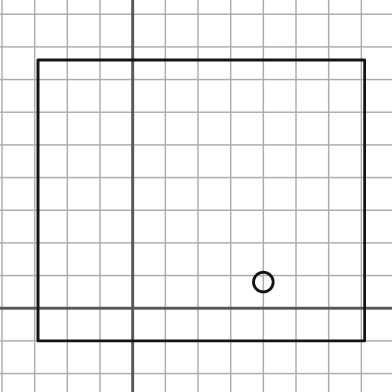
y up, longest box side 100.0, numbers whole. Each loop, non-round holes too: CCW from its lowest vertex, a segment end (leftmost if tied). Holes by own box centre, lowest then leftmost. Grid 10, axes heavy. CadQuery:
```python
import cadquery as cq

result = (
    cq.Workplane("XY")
    .moveTo(-29.0, -10.0)
    .lineTo(71.0, -10.0)
    .lineTo(71.0, 76.0)
    .lineTo(-29.0, 76.0)
    .close()
    .moveTo(40.0, 8.0)
    .circle(3.0)
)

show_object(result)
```